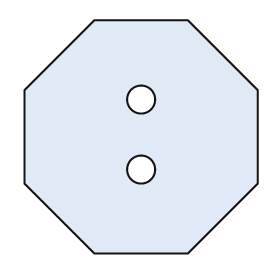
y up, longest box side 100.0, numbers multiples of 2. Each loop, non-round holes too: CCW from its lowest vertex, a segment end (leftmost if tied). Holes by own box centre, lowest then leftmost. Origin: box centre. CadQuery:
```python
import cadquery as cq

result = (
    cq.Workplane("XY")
    .moveTo(-20.0, -50.0)
    .lineTo(20.0, -50.0)
    .lineTo(50.0, -20.0)
    .lineTo(50.0, 20.0)
    .lineTo(20.0, 50.0)
    .lineTo(-20.0, 50.0)
    .lineTo(-50.0, 20.0)
    .lineTo(-50.0, -20.0)
    .close()
    .moveTo(0.0, -14.0)
    .circle(6.0)
    .moveTo(0.0, 16.0)
    .circle(6.0)
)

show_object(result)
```